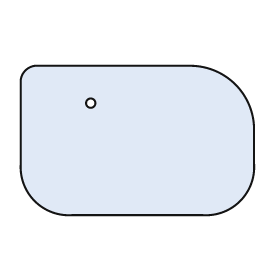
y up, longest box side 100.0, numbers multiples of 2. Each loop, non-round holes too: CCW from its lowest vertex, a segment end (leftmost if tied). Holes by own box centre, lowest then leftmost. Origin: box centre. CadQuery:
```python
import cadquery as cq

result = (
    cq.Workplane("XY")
    .moveTo(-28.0, -32.0)
    .lineTo(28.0, -32.0)
    .threePointArc((44.0, -26.0), (50.0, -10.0))
    .lineTo(50.0, 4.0)
    .threePointArc((42.0, 24.0), (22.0, 32.0))
    .lineTo(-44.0, 32.0)
    .threePointArc((-48.0, 30.0), (-50.0, 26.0))
    .lineTo(-50.0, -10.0)
    .threePointArc((-44.0, -26.0), (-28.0, -32.0))
    .close()
    .moveTo(-20.0, 16.0)
    .circle(2.0)
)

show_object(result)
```